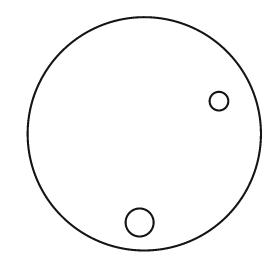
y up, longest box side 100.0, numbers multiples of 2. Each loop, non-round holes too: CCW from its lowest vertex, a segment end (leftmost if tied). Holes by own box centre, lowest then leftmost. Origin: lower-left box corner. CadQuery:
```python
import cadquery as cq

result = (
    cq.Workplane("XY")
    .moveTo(50.0, 50.0)
    .circle(50.0)
    .moveTo(48.0, 12.0)
    .circle(6.0)
    .moveTo(82.0, 64.0)
    .circle(4.0)
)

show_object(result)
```